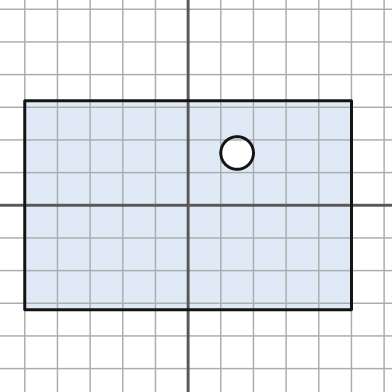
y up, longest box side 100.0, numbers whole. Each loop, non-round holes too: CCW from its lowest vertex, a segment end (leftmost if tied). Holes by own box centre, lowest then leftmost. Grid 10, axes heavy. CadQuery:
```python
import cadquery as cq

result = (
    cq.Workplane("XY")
    .moveTo(-50.0, -32.0)
    .lineTo(50.0, -32.0)
    .lineTo(50.0, 32.0)
    .lineTo(-50.0, 32.0)
    .close()
    .moveTo(15.0, 16.0)
    .circle(5.0)
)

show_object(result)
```